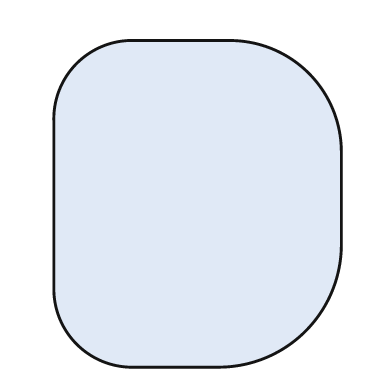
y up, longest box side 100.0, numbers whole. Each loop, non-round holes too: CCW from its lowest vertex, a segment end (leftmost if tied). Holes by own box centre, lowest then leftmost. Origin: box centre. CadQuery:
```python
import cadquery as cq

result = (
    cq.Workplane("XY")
    .moveTo(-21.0, -50.0)
    .lineTo(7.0, -50.0)
    .threePointArc((33.0, -39.0), (44.0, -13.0))
    .lineTo(44.0, 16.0)
    .threePointArc((34.0, 40.0), (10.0, 50.0))
    .lineTo(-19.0, 50.0)
    .threePointArc((-37.0, 43.0), (-44.0, 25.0))
    .lineTo(-44.0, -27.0)
    .threePointArc((-37.0, -43.0), (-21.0, -50.0))
    .close()
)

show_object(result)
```